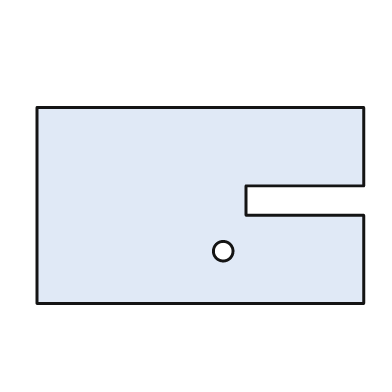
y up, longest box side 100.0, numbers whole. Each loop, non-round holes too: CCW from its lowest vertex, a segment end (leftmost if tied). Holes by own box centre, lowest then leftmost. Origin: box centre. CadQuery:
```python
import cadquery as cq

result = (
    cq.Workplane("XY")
    .moveTo(-50.0, -30.0)
    .lineTo(50.0, -30.0)
    .lineTo(50.0, -3.0)
    .lineTo(14.0, -3.0)
    .lineTo(14.0, 6.0)
    .lineTo(50.0, 6.0)
    .lineTo(50.0, 30.0)
    .lineTo(-50.0, 30.0)
    .close()
    .moveTo(7.0, -14.0)
    .circle(3.0)
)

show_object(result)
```